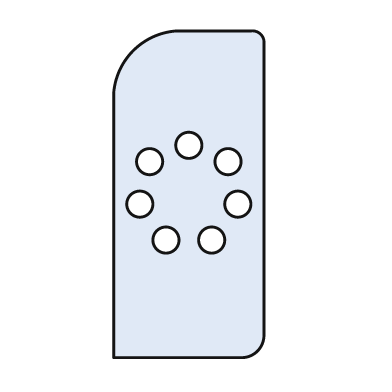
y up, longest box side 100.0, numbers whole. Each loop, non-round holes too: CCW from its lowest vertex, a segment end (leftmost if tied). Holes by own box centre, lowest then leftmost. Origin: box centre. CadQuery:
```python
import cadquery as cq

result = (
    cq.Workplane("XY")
    .moveTo(-23.0, -50.0)
    .lineTo(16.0, -50.0)
    .threePointArc((21.0, -48.0), (23.0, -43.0))
    .lineTo(23.0, 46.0)
    .threePointArc((22.0, 49.0), (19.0, 50.0))
    .lineTo(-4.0, 50.0)
    .threePointArc((-17.0, 44.0), (-23.0, 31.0))
    .close()
    .moveTo(-7.0, -14.0)
    .circle(4.0)
    .moveTo(7.0, -14.0)
    .circle(4.0)
    .moveTo(-15.0, -3.0)
    .circle(4.0)
    .moveTo(15.0, -3.0)
    .circle(4.0)
    .moveTo(-12.0, 10.0)
    .circle(4.0)
    .moveTo(12.0, 10.0)
    .circle(4.0)
    .moveTo(0.0, 15.0)
    .circle(4.0)
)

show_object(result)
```